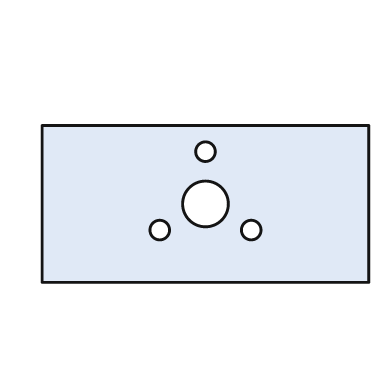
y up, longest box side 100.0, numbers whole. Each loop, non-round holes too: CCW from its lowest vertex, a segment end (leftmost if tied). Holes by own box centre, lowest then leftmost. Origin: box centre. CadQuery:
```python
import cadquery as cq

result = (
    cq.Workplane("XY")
    .moveTo(-50.0, -24.0)
    .lineTo(50.0, -24.0)
    .lineTo(50.0, 24.0)
    .lineTo(-50.0, 24.0)
    .close()
    .moveTo(-14.0, -8.0)
    .circle(3.0)
    .moveTo(14.0, -8.0)
    .circle(3.0)
    .moveTo(0.0, 0.0)
    .circle(7.0)
    .moveTo(0.0, 16.0)
    .circle(3.0)
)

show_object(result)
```